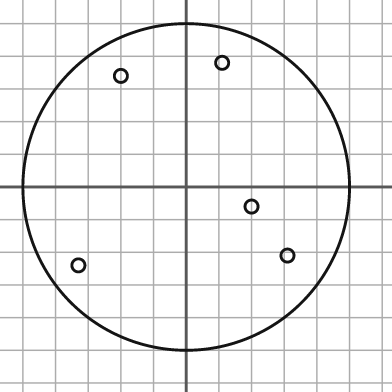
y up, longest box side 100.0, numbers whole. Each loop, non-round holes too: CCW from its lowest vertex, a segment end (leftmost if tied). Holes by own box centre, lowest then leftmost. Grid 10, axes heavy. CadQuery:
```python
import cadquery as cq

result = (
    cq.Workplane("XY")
    .moveTo(0.0, 0.0)
    .circle(50.0)
    .moveTo(-33.0, -24.0)
    .circle(2.0)
    .moveTo(31.0, -21.0)
    .circle(2.0)
    .moveTo(20.0, -6.0)
    .circle(2.0)
    .moveTo(-20.0, 34.0)
    .circle(2.0)
    .moveTo(11.0, 38.0)
    .circle(2.0)
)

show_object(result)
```